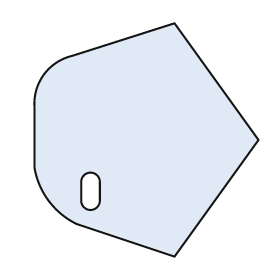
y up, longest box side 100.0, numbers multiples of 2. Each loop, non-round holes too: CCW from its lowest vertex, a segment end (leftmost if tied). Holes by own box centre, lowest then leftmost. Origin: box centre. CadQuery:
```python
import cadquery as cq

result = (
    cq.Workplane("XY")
    .moveTo(12.0, -50.0)
    .lineTo(48.0, 0.0)
    .lineTo(12.0, 50.0)
    .lineTo(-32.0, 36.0)
    .threePointArc((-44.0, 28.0), (-48.0, 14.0))
    .lineTo(-48.0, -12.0)
    .threePointArc((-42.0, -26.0), (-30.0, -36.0))
    .close()
    .moveTo(-28.0, -26.0)
    .threePointArc((-24.0, -30.0), (-20.0, -26.0))
    .lineTo(-20.0, -18.0)
    .threePointArc((-24.0, -14.0), (-28.0, -18.0))
    .close()
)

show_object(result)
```